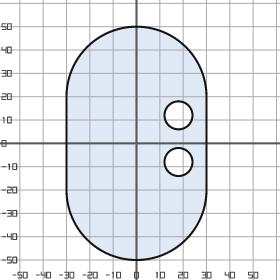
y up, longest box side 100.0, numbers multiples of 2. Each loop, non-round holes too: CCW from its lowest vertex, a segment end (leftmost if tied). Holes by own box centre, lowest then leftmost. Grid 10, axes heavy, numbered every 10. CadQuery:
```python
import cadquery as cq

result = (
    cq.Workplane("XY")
    .moveTo(-30.0, -20.0)
    .threePointArc((0.0, -50.0), (30.0, -20.0))
    .lineTo(30.0, 20.0)
    .threePointArc((0.0, 50.0), (-30.0, 20.0))
    .close()
    .moveTo(18.0, -8.0)
    .circle(6.0)
    .moveTo(18.0, 12.0)
    .circle(6.0)
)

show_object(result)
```